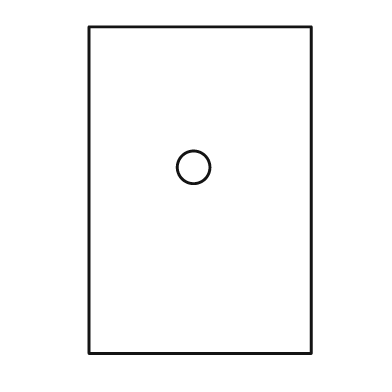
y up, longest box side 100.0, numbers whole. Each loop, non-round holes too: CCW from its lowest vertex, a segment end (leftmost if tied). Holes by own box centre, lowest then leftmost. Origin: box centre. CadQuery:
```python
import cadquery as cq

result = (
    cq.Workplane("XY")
    .moveTo(-34.0, -50.0)
    .lineTo(34.0, -50.0)
    .lineTo(34.0, 50.0)
    .lineTo(-34.0, 50.0)
    .close()
    .moveTo(-2.0, 7.0)
    .circle(5.0)
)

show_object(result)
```